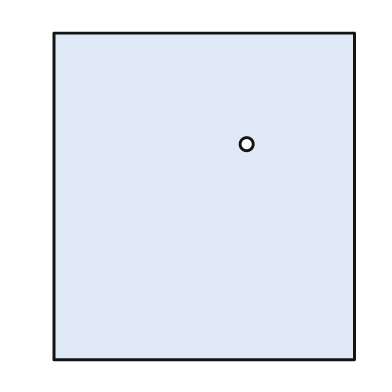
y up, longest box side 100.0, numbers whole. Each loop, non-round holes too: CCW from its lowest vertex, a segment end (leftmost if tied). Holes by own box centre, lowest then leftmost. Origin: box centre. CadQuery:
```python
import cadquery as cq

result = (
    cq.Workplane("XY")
    .moveTo(-46.0, -50.0)
    .lineTo(46.0, -50.0)
    .lineTo(46.0, 50.0)
    .lineTo(-46.0, 50.0)
    .close()
    .moveTo(13.0, 16.0)
    .circle(2.0)
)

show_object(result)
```